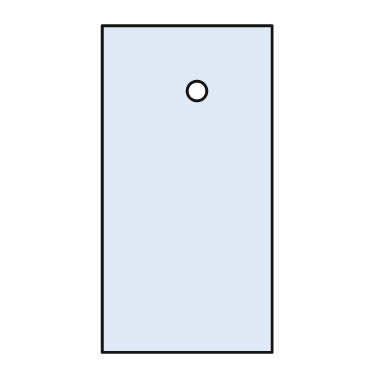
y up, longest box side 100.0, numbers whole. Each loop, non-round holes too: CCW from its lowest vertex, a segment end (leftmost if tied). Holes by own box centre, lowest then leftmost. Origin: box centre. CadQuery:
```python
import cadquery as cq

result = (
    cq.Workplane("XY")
    .moveTo(-26.0, -50.0)
    .lineTo(26.0, -50.0)
    .lineTo(26.0, 50.0)
    .lineTo(-26.0, 50.0)
    .close()
    .moveTo(3.0, 30.0)
    .circle(3.0)
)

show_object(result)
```